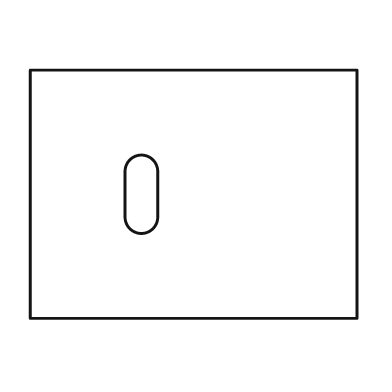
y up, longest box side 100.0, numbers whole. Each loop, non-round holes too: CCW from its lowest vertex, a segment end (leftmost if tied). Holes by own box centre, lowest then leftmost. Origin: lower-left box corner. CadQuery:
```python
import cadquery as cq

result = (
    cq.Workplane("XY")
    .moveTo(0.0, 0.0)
    .lineTo(100.0, 0.0)
    .lineTo(100.0, 76.0)
    .lineTo(0.0, 76.0)
    .close()
    .moveTo(29.0, 31.0)
    .threePointArc((34.0, 26.0), (39.0, 31.0))
    .lineTo(39.0, 45.0)
    .threePointArc((34.0, 50.0), (29.0, 45.0))
    .close()
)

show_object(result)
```